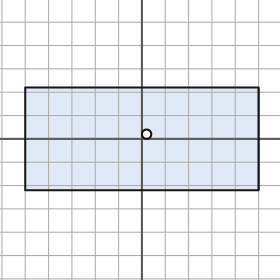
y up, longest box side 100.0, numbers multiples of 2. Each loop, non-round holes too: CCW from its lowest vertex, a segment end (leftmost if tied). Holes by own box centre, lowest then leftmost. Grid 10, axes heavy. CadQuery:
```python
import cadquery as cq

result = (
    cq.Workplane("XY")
    .moveTo(-50.0, -22.0)
    .lineTo(50.0, -22.0)
    .lineTo(50.0, 22.0)
    .lineTo(-50.0, 22.0)
    .close()
    .moveTo(2.0, 2.0)
    .circle(2.0)
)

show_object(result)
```